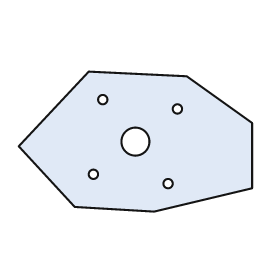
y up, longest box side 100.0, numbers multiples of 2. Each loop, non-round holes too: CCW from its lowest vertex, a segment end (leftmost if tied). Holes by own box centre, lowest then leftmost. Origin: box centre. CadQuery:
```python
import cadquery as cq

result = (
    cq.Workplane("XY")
    .moveTo(8.0, -30.0)
    .lineTo(50.0, -20.0)
    .lineTo(50.0, 8.0)
    .lineTo(22.0, 28.0)
    .lineTo(-20.0, 30.0)
    .lineTo(-50.0, -2.0)
    .lineTo(-26.0, -28.0)
    .close()
    .moveTo(14.0, -18.0)
    .circle(2.0)
    .moveTo(-18.0, -14.0)
    .circle(2.0)
    .moveTo(0.0, 0.0)
    .circle(6.0)
    .moveTo(18.0, 14.0)
    .circle(2.0)
    .moveTo(-14.0, 18.0)
    .circle(2.0)
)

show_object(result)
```